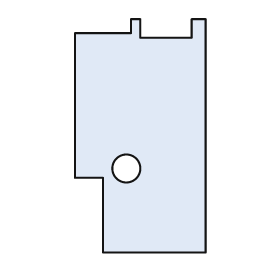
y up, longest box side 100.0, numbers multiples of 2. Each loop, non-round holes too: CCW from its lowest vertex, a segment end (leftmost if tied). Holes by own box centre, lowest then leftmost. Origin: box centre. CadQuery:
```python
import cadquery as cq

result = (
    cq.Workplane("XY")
    .moveTo(-16.0, -50.0)
    .lineTo(28.0, -50.0)
    .lineTo(28.0, 50.0)
    .lineTo(22.0, 50.0)
    .lineTo(22.0, 42.0)
    .lineTo(0.0, 42.0)
    .lineTo(0.0, 50.0)
    .lineTo(-4.0, 50.0)
    .lineTo(-4.0, 44.0)
    .lineTo(-28.0, 44.0)
    .lineTo(-28.0, -18.0)
    .lineTo(-16.0, -18.0)
    .close()
    .moveTo(-6.0, -14.0)
    .circle(6.0)
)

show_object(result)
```